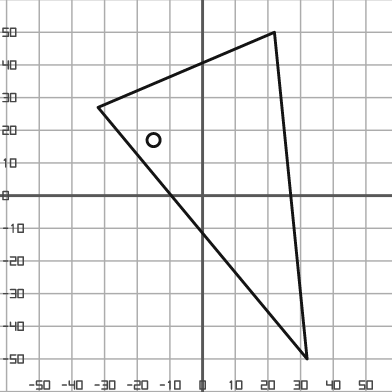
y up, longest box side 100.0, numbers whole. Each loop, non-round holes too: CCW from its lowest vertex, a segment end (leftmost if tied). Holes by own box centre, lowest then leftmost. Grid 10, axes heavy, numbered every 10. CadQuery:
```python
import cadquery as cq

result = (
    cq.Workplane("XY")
    .moveTo(32.0, -50.0)
    .lineTo(22.0, 50.0)
    .lineTo(-32.0, 27.0)
    .close()
    .moveTo(-15.0, 17.0)
    .circle(2.0)
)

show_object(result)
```